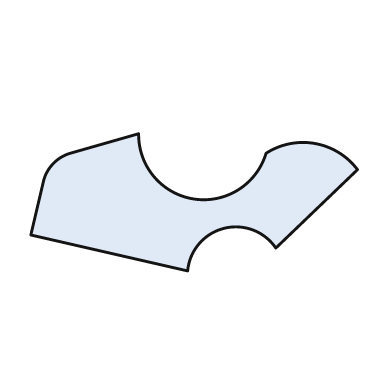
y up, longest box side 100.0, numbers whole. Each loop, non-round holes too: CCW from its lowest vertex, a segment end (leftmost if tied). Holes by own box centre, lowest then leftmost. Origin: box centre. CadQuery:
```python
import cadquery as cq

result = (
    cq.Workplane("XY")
    .moveTo(-2.0, -21.0)
    .threePointArc((9.0, -8.0), (25.0, -14.0))
    .lineTo(50.0, 10.0)
    .threePointArc((37.0, 18.0), (22.0, 15.0))
    .threePointArc((0.0, 1.0), (-17.0, 21.0))
    .lineTo(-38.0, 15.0)
    .threePointArc((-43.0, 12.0), (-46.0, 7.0))
    .lineTo(-50.0, -10.0)
    .close()
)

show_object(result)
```